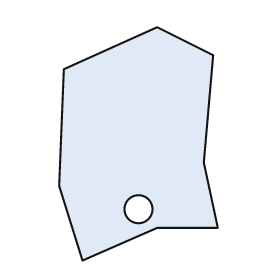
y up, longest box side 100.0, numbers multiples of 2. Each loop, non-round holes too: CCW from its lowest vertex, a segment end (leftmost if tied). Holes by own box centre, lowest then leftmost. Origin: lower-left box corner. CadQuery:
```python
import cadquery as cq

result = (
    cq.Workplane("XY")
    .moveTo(10.0, 0.0)
    .lineTo(42.0, 14.0)
    .lineTo(68.0, 14.0)
    .lineTo(62.0, 42.0)
    .lineTo(66.0, 88.0)
    .lineTo(42.0, 100.0)
    .lineTo(2.0, 82.0)
    .lineTo(0.0, 32.0)
    .close()
    .moveTo(34.0, 22.0)
    .circle(6.0)
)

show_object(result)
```